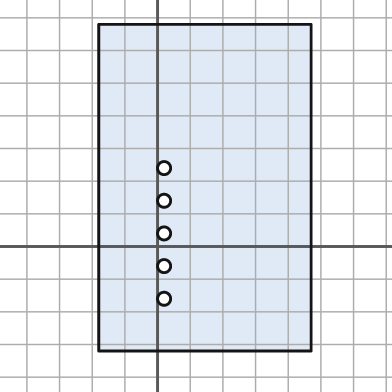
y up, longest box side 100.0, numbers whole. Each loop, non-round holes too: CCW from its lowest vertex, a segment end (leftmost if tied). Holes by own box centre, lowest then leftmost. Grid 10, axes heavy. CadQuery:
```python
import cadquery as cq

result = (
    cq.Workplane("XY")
    .moveTo(-18.0, -32.0)
    .lineTo(47.0, -32.0)
    .lineTo(47.0, 68.0)
    .lineTo(-18.0, 68.0)
    .close()
    .moveTo(2.0, -16.0)
    .circle(2.0)
    .moveTo(2.0, -6.0)
    .circle(2.0)
    .moveTo(2.0, 4.0)
    .circle(2.0)
    .moveTo(2.0, 14.0)
    .circle(2.0)
    .moveTo(2.0, 24.0)
    .circle(2.0)
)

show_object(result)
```